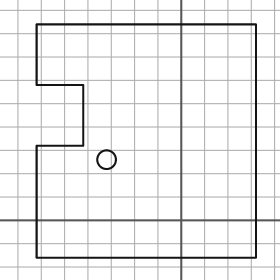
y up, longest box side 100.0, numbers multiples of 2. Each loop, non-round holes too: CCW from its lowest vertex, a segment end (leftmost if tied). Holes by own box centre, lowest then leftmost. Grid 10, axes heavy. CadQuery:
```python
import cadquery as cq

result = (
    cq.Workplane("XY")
    .moveTo(-62.0, -16.0)
    .lineTo(32.0, -16.0)
    .lineTo(32.0, 84.0)
    .lineTo(-62.0, 84.0)
    .lineTo(-62.0, 58.0)
    .lineTo(-42.0, 58.0)
    .lineTo(-42.0, 32.0)
    .lineTo(-62.0, 32.0)
    .close()
    .moveTo(-32.0, 26.0)
    .circle(4.0)
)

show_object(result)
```